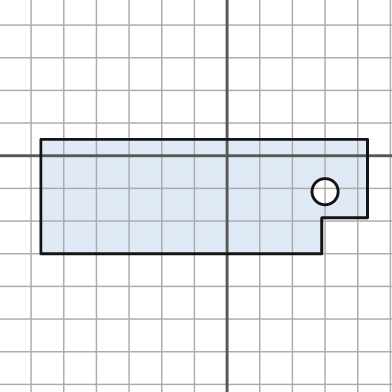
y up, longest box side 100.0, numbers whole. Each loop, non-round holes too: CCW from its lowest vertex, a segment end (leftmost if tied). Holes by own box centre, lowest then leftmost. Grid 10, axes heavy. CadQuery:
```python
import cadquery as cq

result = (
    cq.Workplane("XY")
    .moveTo(-57.0, -30.0)
    .lineTo(29.0, -30.0)
    .lineTo(29.0, -19.0)
    .lineTo(43.0, -19.0)
    .lineTo(43.0, 5.0)
    .lineTo(-57.0, 5.0)
    .close()
    .moveTo(30.0, -11.0)
    .circle(4.0)
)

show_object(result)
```